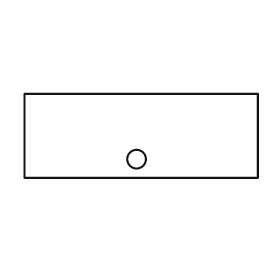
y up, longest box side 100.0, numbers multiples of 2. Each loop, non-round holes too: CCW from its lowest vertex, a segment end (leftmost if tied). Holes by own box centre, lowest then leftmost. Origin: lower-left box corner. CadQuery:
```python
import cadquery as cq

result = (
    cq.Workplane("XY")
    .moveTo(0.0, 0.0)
    .lineTo(100.0, 0.0)
    .lineTo(100.0, 36.0)
    .lineTo(0.0, 36.0)
    .close()
    .moveTo(48.0, 8.0)
    .circle(4.0)
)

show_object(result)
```